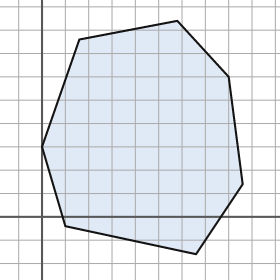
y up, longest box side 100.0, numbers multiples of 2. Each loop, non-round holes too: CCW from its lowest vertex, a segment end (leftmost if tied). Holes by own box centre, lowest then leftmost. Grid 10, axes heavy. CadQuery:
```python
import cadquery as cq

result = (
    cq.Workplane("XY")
    .moveTo(66.0, -16.0)
    .lineTo(86.0, 14.0)
    .lineTo(80.0, 60.0)
    .lineTo(58.0, 84.0)
    .lineTo(16.0, 76.0)
    .lineTo(0.0, 30.0)
    .lineTo(10.0, -4.0)
    .close()
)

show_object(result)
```